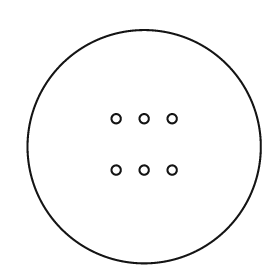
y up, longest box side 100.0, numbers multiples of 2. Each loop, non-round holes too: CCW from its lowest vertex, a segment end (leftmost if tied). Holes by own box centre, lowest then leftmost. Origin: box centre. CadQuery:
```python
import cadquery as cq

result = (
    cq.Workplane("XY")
    .moveTo(0.0, 0.0)
    .circle(50.0)
    .moveTo(-12.0, -10.0)
    .circle(2.0)
    .moveTo(0.0, -10.0)
    .circle(2.0)
    .moveTo(12.0, -10.0)
    .circle(2.0)
    .moveTo(-12.0, 12.0)
    .circle(2.0)
    .moveTo(0.0, 12.0)
    .circle(2.0)
    .moveTo(12.0, 12.0)
    .circle(2.0)
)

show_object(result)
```